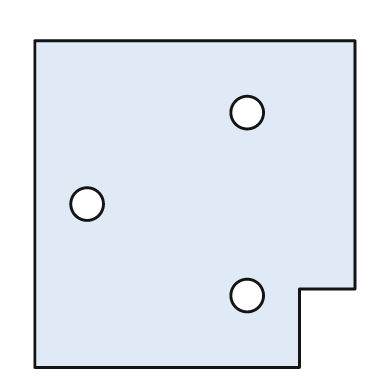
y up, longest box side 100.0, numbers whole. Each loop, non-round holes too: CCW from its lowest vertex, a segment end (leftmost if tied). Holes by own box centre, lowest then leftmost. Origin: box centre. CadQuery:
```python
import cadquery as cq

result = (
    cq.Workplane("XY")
    .moveTo(-49.0, -50.0)
    .lineTo(32.0, -50.0)
    .lineTo(32.0, -26.0)
    .lineTo(49.0, -26.0)
    .lineTo(49.0, 50.0)
    .lineTo(-49.0, 50.0)
    .close()
    .moveTo(16.0, -28.0)
    .circle(5.0)
    .moveTo(-33.0, 0.0)
    .circle(5.0)
    .moveTo(16.0, 28.0)
    .circle(5.0)
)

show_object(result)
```